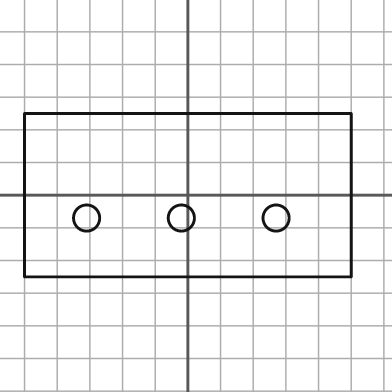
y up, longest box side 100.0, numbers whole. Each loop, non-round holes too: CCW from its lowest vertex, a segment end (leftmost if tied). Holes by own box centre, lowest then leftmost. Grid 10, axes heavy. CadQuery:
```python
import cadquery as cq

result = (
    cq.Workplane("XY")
    .moveTo(-50.0, -25.0)
    .lineTo(50.0, -25.0)
    .lineTo(50.0, 25.0)
    .lineTo(-50.0, 25.0)
    .close()
    .moveTo(-31.0, -7.0)
    .circle(4.0)
    .moveTo(-2.0, -7.0)
    .circle(4.0)
    .moveTo(27.0, -7.0)
    .circle(4.0)
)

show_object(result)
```